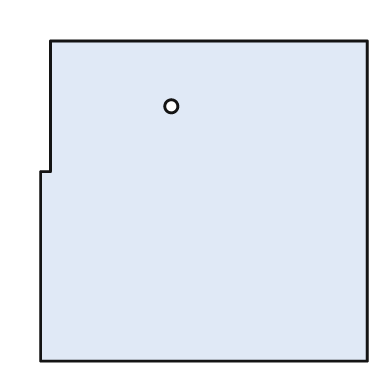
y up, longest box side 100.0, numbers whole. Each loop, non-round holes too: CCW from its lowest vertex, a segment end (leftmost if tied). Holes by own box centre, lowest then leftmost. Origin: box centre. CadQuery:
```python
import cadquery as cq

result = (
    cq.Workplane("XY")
    .moveTo(-50.0, -49.0)
    .lineTo(50.0, -49.0)
    .lineTo(50.0, 49.0)
    .lineTo(-47.0, 49.0)
    .lineTo(-47.0, 9.0)
    .lineTo(-50.0, 9.0)
    .close()
    .moveTo(-10.0, 29.0)
    .circle(2.0)
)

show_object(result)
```